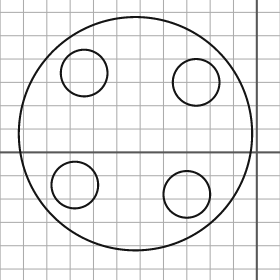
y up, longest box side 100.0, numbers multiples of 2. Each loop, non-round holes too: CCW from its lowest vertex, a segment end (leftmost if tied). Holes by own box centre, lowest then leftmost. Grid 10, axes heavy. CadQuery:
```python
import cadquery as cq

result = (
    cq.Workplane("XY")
    .moveTo(-52.0, 8.0)
    .circle(50.0)
    .moveTo(-30.0, -18.0)
    .circle(10.0)
    .moveTo(-78.0, -14.0)
    .circle(10.0)
    .moveTo(-26.0, 30.0)
    .circle(10.0)
    .moveTo(-74.0, 34.0)
    .circle(10.0)
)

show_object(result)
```